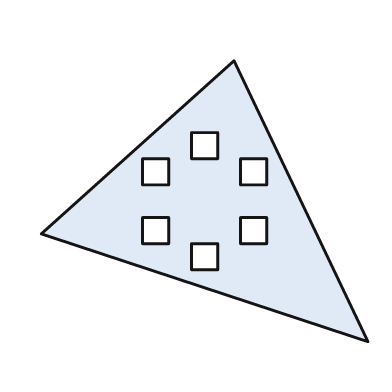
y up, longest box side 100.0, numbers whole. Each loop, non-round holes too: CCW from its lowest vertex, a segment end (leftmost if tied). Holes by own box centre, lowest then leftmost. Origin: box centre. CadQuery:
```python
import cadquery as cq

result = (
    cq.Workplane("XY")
    .moveTo(50.0, -43.0)
    .lineTo(9.0, 43.0)
    .lineTo(-50.0, -10.0)
    .close()
    .moveTo(-4.0, -21.0)
    .lineTo(4.0, -21.0)
    .lineTo(4.0, -13.0)
    .lineTo(-4.0, -13.0)
    .close()
    .moveTo(-19.0, -13.0)
    .lineTo(-11.0, -13.0)
    .lineTo(-11.0, -5.0)
    .lineTo(-19.0, -5.0)
    .close()
    .moveTo(11.0, -13.0)
    .lineTo(19.0, -13.0)
    .lineTo(19.0, -5.0)
    .lineTo(11.0, -5.0)
    .close()
    .moveTo(-19.0, 5.0)
    .lineTo(-11.0, 5.0)
    .lineTo(-11.0, 13.0)
    .lineTo(-19.0, 13.0)
    .close()
    .moveTo(11.0, 5.0)
    .lineTo(19.0, 5.0)
    .lineTo(19.0, 13.0)
    .lineTo(11.0, 13.0)
    .close()
    .moveTo(-4.0, 13.0)
    .lineTo(4.0, 13.0)
    .lineTo(4.0, 21.0)
    .lineTo(-4.0, 21.0)
    .close()
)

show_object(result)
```